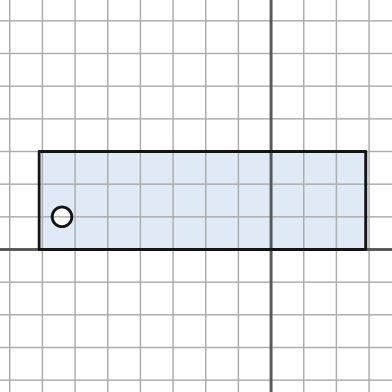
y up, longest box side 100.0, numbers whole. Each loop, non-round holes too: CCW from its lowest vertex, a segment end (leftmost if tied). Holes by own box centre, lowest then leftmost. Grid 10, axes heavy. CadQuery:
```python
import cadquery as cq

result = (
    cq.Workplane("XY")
    .moveTo(-71.0, 0.0)
    .lineTo(29.0, 0.0)
    .lineTo(29.0, 30.0)
    .lineTo(-71.0, 30.0)
    .close()
    .moveTo(-64.0, 10.0)
    .circle(3.0)
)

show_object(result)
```